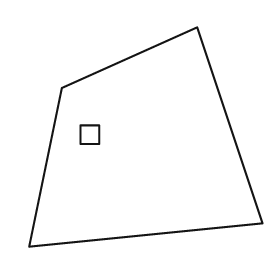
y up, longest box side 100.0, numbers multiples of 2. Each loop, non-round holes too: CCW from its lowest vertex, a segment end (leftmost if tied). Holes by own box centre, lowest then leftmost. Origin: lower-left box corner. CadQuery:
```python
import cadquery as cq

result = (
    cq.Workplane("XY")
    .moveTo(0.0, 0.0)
    .lineTo(100.0, 10.0)
    .lineTo(72.0, 94.0)
    .lineTo(14.0, 68.0)
    .close()
    .moveTo(22.0, 44.0)
    .lineTo(30.0, 44.0)
    .lineTo(30.0, 52.0)
    .lineTo(22.0, 52.0)
    .close()
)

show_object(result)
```